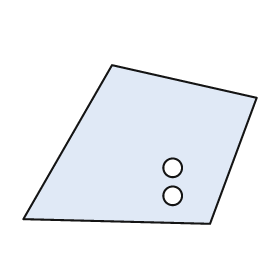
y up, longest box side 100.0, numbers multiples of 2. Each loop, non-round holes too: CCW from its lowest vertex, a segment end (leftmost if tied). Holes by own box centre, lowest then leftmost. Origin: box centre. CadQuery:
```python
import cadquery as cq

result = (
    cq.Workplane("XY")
    .moveTo(30.0, -34.0)
    .lineTo(50.0, 20.0)
    .lineTo(-12.0, 34.0)
    .lineTo(-50.0, -32.0)
    .close()
    .moveTo(14.0, -22.0)
    .circle(4.0)
    .moveTo(14.0, -10.0)
    .circle(4.0)
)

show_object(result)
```